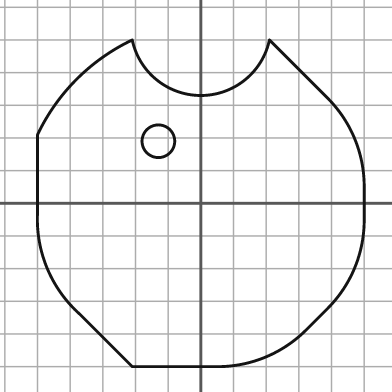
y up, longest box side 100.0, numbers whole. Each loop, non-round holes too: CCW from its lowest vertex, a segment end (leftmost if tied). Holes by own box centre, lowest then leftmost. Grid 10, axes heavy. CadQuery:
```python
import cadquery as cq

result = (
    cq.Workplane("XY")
    .moveTo(-21.0, -50.0)
    .lineTo(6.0, -50.0)
    .threePointArc((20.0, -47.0), (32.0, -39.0))
    .lineTo(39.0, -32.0)
    .threePointArc((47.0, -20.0), (50.0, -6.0))
    .lineTo(50.0, 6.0)
    .threePointArc((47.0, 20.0), (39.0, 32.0))
    .lineTo(21.0, 50.0)
    .threePointArc((0.0, 33.0), (-21.0, 50.0))
    .threePointArc((-38.0, 38.0), (-50.0, 21.0))
    .lineTo(-50.0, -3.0)
    .threePointArc((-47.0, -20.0), (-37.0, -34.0))
    .close()
    .moveTo(-13.0, 19.0)
    .circle(5.0)
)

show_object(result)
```